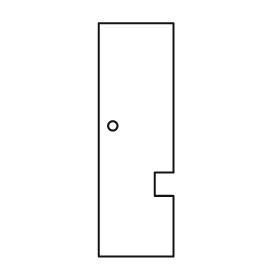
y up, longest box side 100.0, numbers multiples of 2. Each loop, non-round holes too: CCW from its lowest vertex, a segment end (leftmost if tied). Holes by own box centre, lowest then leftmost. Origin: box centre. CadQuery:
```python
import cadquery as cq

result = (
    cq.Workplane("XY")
    .moveTo(-16.0, -50.0)
    .lineTo(16.0, -50.0)
    .lineTo(16.0, -24.0)
    .lineTo(8.0, -24.0)
    .lineTo(8.0, -14.0)
    .lineTo(16.0, -14.0)
    .lineTo(16.0, 50.0)
    .lineTo(-16.0, 50.0)
    .close()
    .moveTo(-10.0, 6.0)
    .circle(2.0)
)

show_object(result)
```